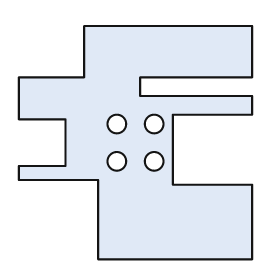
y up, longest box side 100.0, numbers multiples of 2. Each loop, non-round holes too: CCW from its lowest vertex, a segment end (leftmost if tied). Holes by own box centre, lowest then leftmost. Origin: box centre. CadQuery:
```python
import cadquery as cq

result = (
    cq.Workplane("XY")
    .moveTo(-16.0, -50.0)
    .lineTo(50.0, -50.0)
    .lineTo(50.0, -18.0)
    .lineTo(16.0, -18.0)
    .lineTo(16.0, 12.0)
    .lineTo(50.0, 12.0)
    .lineTo(50.0, 20.0)
    .lineTo(2.0, 20.0)
    .lineTo(2.0, 28.0)
    .lineTo(50.0, 28.0)
    .lineTo(50.0, 50.0)
    .lineTo(-22.0, 50.0)
    .lineTo(-22.0, 28.0)
    .lineTo(-50.0, 28.0)
    .lineTo(-50.0, 10.0)
    .lineTo(-30.0, 10.0)
    .lineTo(-30.0, -10.0)
    .lineTo(-50.0, -10.0)
    .lineTo(-50.0, -16.0)
    .lineTo(-16.0, -16.0)
    .close()
    .moveTo(-8.0, -8.0)
    .circle(4.0)
    .moveTo(8.0, -8.0)
    .circle(4.0)
    .moveTo(-8.0, 8.0)
    .circle(4.0)
    .moveTo(8.0, 8.0)
    .circle(4.0)
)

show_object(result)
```